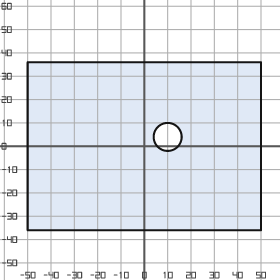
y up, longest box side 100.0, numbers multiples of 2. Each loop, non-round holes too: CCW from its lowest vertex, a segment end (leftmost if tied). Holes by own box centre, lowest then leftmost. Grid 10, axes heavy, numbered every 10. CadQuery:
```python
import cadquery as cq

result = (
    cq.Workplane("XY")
    .moveTo(-50.0, -36.0)
    .lineTo(50.0, -36.0)
    .lineTo(50.0, 36.0)
    .lineTo(-50.0, 36.0)
    .close()
    .moveTo(10.0, 4.0)
    .circle(6.0)
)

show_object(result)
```